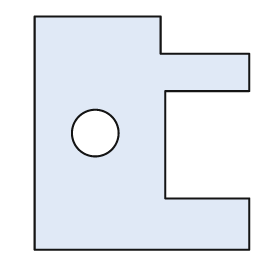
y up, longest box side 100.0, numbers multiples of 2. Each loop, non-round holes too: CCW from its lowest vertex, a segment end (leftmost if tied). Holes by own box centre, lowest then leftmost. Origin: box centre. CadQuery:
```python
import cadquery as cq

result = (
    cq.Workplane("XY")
    .moveTo(-46.0, -50.0)
    .lineTo(46.0, -50.0)
    .lineTo(46.0, -28.0)
    .lineTo(10.0, -28.0)
    .lineTo(10.0, 18.0)
    .lineTo(46.0, 18.0)
    .lineTo(46.0, 34.0)
    .lineTo(8.0, 34.0)
    .lineTo(8.0, 50.0)
    .lineTo(-46.0, 50.0)
    .close()
    .moveTo(-20.0, 0.0)
    .circle(10.0)
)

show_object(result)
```